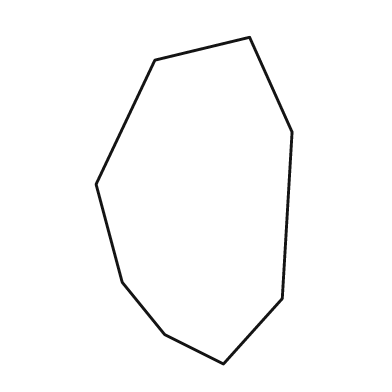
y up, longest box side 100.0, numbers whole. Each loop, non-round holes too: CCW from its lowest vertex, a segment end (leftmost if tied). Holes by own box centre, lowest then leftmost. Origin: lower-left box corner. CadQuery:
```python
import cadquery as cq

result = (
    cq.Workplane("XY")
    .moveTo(39.0, 0.0)
    .lineTo(57.0, 20.0)
    .lineTo(60.0, 71.0)
    .lineTo(47.0, 100.0)
    .lineTo(18.0, 93.0)
    .lineTo(0.0, 55.0)
    .lineTo(8.0, 25.0)
    .lineTo(21.0, 9.0)
    .close()
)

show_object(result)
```